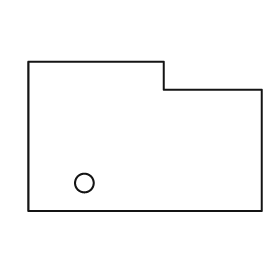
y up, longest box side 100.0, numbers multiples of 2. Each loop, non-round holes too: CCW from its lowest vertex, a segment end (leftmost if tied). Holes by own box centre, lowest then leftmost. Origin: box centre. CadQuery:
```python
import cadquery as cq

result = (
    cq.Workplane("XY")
    .moveTo(-50.0, -32.0)
    .lineTo(50.0, -32.0)
    .lineTo(50.0, 20.0)
    .lineTo(8.0, 20.0)
    .lineTo(8.0, 32.0)
    .lineTo(-50.0, 32.0)
    .close()
    .moveTo(-26.0, -20.0)
    .circle(4.0)
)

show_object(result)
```